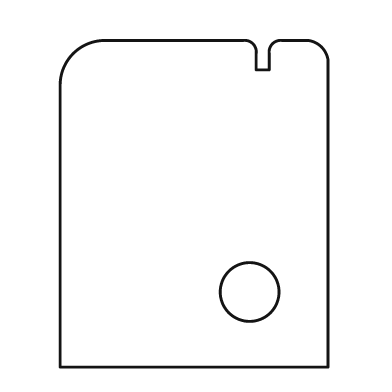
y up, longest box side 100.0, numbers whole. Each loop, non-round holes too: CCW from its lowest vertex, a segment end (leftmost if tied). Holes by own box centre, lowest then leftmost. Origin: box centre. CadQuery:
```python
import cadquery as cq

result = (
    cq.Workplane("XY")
    .moveTo(-41.0, -50.0)
    .lineTo(41.0, -50.0)
    .lineTo(41.0, 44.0)
    .threePointArc((39.0, 48.0), (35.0, 50.0))
    .lineTo(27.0, 50.0)
    .threePointArc((24.0, 49.0), (23.0, 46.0))
    .lineTo(23.0, 41.0)
    .lineTo(19.0, 41.0)
    .lineTo(19.0, 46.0)
    .threePointArc((18.0, 49.0), (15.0, 50.0))
    .lineTo(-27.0, 50.0)
    .threePointArc((-37.0, 46.0), (-41.0, 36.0))
    .close()
    .moveTo(17.0, -27.0)
    .circle(9.0)
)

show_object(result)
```